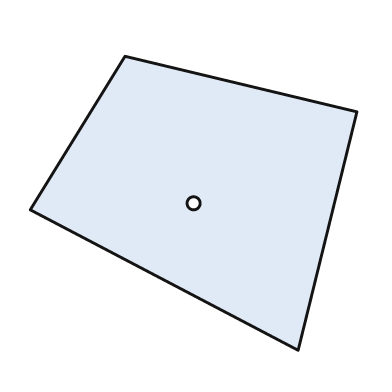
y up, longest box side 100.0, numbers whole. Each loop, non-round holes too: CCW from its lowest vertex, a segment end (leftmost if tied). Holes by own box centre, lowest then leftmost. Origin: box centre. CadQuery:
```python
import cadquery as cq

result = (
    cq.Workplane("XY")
    .moveTo(32.0, -45.0)
    .lineTo(50.0, 28.0)
    .lineTo(-21.0, 45.0)
    .lineTo(-50.0, -2.0)
    .close()
    .moveTo(0.0, 0.0)
    .circle(2.0)
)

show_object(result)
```